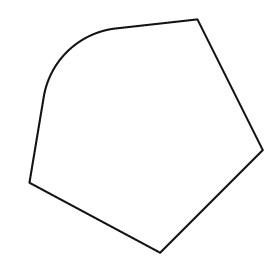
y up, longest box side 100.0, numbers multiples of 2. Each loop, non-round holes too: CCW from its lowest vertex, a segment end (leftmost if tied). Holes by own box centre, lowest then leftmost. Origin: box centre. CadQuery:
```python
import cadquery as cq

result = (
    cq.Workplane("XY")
    .moveTo(6.0, -50.0)
    .lineTo(50.0, -6.0)
    .lineTo(22.0, 50.0)
    .lineTo(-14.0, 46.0)
    .threePointArc((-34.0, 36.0), (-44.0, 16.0))
    .lineTo(-50.0, -20.0)
    .close()
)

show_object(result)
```